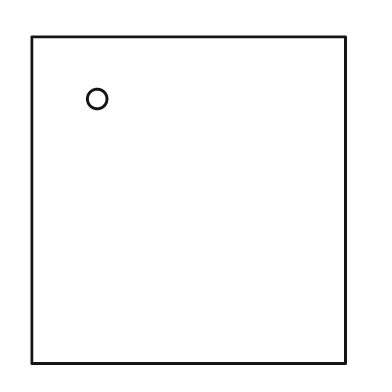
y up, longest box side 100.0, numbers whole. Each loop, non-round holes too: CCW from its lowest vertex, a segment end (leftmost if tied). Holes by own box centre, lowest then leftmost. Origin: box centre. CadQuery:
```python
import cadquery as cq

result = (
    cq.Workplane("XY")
    .moveTo(-48.0, -50.0)
    .lineTo(48.0, -50.0)
    .lineTo(48.0, 50.0)
    .lineTo(-48.0, 50.0)
    .close()
    .moveTo(-28.0, 31.0)
    .circle(3.0)
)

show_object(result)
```